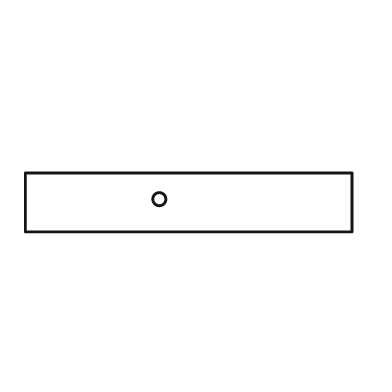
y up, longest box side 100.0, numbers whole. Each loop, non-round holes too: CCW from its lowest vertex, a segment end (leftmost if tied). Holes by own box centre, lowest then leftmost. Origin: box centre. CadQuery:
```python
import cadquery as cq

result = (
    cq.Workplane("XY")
    .moveTo(-50.0, -9.0)
    .lineTo(50.0, -9.0)
    .lineTo(50.0, 9.0)
    .lineTo(-50.0, 9.0)
    .close()
    .moveTo(-9.0, 1.0)
    .circle(2.0)
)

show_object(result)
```